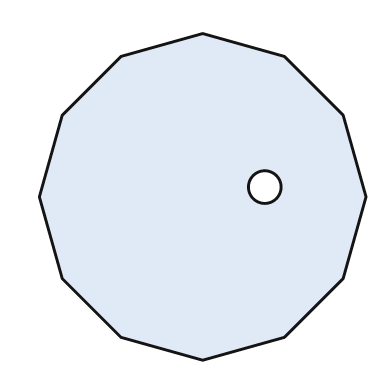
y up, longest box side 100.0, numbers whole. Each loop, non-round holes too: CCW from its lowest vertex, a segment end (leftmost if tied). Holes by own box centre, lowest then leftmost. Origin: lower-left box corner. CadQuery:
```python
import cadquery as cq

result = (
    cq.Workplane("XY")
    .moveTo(50.0, 0.0)
    .lineTo(75.0, 7.0)
    .lineTo(93.0, 25.0)
    .lineTo(100.0, 50.0)
    .lineTo(93.0, 75.0)
    .lineTo(75.0, 93.0)
    .lineTo(50.0, 100.0)
    .lineTo(25.0, 93.0)
    .lineTo(7.0, 75.0)
    .lineTo(0.0, 50.0)
    .lineTo(7.0, 25.0)
    .lineTo(25.0, 7.0)
    .close()
    .moveTo(69.0, 53.0)
    .circle(5.0)
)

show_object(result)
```